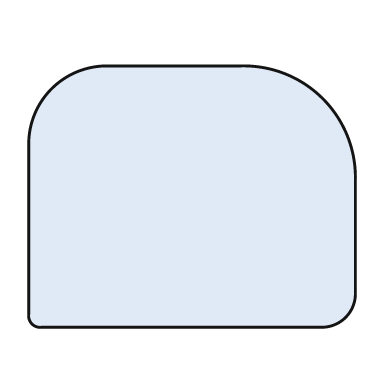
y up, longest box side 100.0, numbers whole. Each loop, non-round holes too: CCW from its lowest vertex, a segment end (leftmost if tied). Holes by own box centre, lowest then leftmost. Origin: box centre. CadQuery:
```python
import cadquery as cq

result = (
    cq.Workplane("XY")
    .moveTo(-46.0, -40.0)
    .lineTo(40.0, -40.0)
    .threePointArc((47.0, -37.0), (50.0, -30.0))
    .lineTo(50.0, 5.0)
    .threePointArc((40.0, 30.0), (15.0, 40.0))
    .lineTo(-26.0, 40.0)
    .threePointArc((-43.0, 33.0), (-50.0, 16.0))
    .lineTo(-50.0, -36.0)
    .threePointArc((-49.0, -39.0), (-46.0, -40.0))
    .close()
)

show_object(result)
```